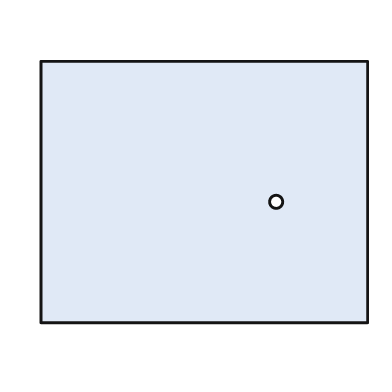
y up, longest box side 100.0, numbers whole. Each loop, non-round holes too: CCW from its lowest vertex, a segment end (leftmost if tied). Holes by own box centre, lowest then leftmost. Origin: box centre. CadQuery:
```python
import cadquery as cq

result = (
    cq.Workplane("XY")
    .moveTo(-50.0, -40.0)
    .lineTo(50.0, -40.0)
    .lineTo(50.0, 40.0)
    .lineTo(-50.0, 40.0)
    .close()
    .moveTo(22.0, -3.0)
    .circle(2.0)
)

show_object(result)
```